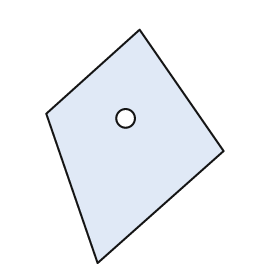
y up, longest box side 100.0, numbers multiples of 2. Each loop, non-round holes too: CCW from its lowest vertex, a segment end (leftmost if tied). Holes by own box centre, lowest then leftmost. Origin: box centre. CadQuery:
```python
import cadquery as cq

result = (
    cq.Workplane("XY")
    .moveTo(-16.0, -50.0)
    .lineTo(38.0, -2.0)
    .lineTo(2.0, 50.0)
    .lineTo(-38.0, 14.0)
    .close()
    .moveTo(-4.0, 12.0)
    .circle(4.0)
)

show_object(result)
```